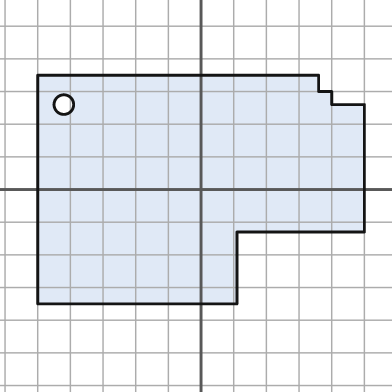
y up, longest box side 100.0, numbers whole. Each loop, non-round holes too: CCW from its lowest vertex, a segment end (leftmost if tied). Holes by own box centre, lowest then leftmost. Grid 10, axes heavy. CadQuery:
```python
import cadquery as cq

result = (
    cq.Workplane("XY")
    .moveTo(-50.0, -35.0)
    .lineTo(11.0, -35.0)
    .lineTo(11.0, -13.0)
    .lineTo(50.0, -13.0)
    .lineTo(50.0, 26.0)
    .lineTo(40.0, 26.0)
    .lineTo(40.0, 30.0)
    .lineTo(36.0, 30.0)
    .lineTo(36.0, 35.0)
    .lineTo(-50.0, 35.0)
    .close()
    .moveTo(-42.0, 26.0)
    .circle(3.0)
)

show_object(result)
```